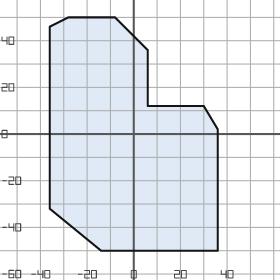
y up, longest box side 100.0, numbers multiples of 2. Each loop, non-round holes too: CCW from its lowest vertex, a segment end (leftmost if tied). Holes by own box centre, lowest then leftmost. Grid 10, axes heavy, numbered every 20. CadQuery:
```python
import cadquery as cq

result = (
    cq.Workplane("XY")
    .moveTo(-14.0, -50.0)
    .lineTo(36.0, -50.0)
    .lineTo(36.0, 2.0)
    .lineTo(30.0, 12.0)
    .lineTo(6.0, 12.0)
    .lineTo(6.0, 36.0)
    .lineTo(-8.0, 50.0)
    .lineTo(-28.0, 50.0)
    .lineTo(-36.0, 46.0)
    .lineTo(-36.0, -32.0)
    .close()
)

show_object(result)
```